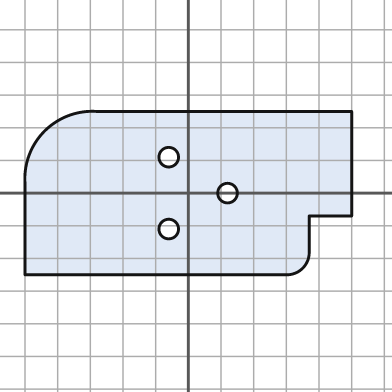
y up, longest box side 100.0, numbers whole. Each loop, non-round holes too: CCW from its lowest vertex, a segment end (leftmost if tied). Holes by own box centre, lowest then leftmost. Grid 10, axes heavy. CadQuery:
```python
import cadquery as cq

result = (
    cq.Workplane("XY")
    .moveTo(-50.0, -25.0)
    .lineTo(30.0, -25.0)
    .threePointArc((35.0, -23.0), (37.0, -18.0))
    .lineTo(37.0, -7.0)
    .lineTo(50.0, -7.0)
    .lineTo(50.0, 25.0)
    .lineTo(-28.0, 25.0)
    .threePointArc((-44.0, 19.0), (-50.0, 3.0))
    .close()
    .moveTo(-6.0, -11.0)
    .circle(3.0)
    .moveTo(12.0, 0.0)
    .circle(3.0)
    .moveTo(-6.0, 11.0)
    .circle(3.0)
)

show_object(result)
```